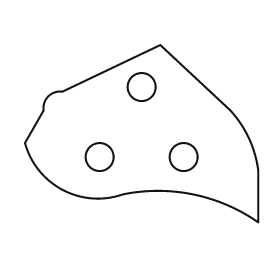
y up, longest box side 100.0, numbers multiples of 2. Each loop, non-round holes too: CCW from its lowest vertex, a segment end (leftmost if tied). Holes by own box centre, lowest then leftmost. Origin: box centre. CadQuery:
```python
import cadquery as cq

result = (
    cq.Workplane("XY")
    .moveTo(50.0, -38.0)
    .lineTo(50.0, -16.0)
    .threePointArc((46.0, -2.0), (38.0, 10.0))
    .lineTo(8.0, 38.0)
    .lineTo(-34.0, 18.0)
    .threePointArc((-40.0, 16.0), (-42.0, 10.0))
    .lineTo(-50.0, -4.0)
    .threePointArc((-34.0, -24.0), (-8.0, -26.0))
    .threePointArc((22.0, -26.0), (50.0, -38.0))
    .close()
    .moveTo(-18.0, -10.0)
    .circle(6.0)
    .moveTo(18.0, -10.0)
    .circle(6.0)
    .moveTo(0.0, 20.0)
    .circle(6.0)
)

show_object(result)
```